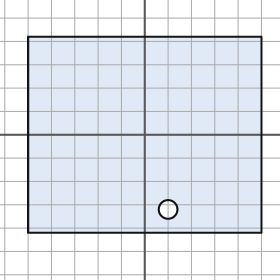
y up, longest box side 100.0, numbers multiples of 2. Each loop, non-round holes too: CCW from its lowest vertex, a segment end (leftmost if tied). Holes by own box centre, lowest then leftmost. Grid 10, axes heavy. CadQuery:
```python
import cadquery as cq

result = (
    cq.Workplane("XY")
    .moveTo(-50.0, -42.0)
    .lineTo(50.0, -42.0)
    .lineTo(50.0, 42.0)
    .lineTo(-50.0, 42.0)
    .close()
    .moveTo(10.0, -32.0)
    .circle(4.0)
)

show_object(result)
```